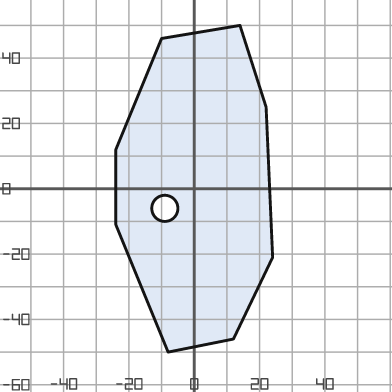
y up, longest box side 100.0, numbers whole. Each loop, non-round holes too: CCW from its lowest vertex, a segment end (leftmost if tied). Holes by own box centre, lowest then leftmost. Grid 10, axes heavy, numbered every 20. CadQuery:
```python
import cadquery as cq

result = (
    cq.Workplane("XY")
    .moveTo(-8.0, -50.0)
    .lineTo(12.0, -46.0)
    .lineTo(24.0, -21.0)
    .lineTo(22.0, 25.0)
    .lineTo(14.0, 50.0)
    .lineTo(-10.0, 46.0)
    .lineTo(-24.0, 12.0)
    .lineTo(-24.0, -11.0)
    .close()
    .moveTo(-9.0, -6.0)
    .circle(4.0)
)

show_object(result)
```